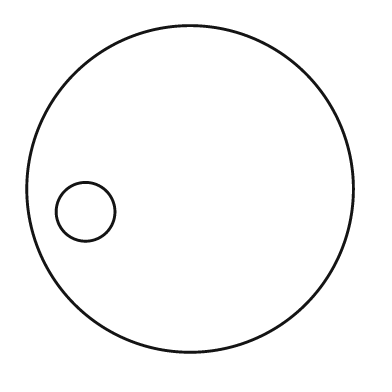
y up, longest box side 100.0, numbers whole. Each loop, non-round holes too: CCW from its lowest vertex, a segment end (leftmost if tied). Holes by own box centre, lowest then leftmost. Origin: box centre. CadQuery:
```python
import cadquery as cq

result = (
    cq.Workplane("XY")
    .moveTo(0.0, 0.0)
    .circle(50.0)
    .moveTo(-32.0, -7.0)
    .circle(9.0)
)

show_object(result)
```